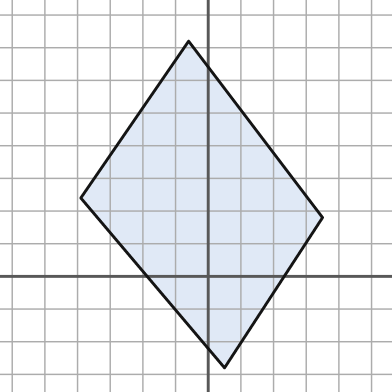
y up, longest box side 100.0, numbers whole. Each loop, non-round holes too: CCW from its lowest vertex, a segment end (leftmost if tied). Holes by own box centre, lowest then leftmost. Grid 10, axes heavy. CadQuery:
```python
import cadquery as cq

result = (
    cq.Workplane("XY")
    .moveTo(5.0, -28.0)
    .lineTo(35.0, 18.0)
    .lineTo(-6.0, 72.0)
    .lineTo(-39.0, 24.0)
    .close()
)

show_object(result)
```